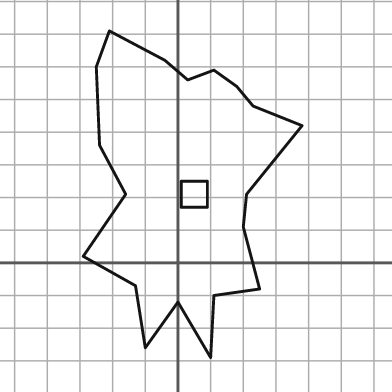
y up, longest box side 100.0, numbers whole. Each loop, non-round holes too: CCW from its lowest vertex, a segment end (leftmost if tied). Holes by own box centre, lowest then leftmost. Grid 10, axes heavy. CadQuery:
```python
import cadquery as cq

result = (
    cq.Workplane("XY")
    .moveTo(10.0, -29.0)
    .lineTo(11.0, -10.0)
    .lineTo(25.0, -8.0)
    .lineTo(20.0, 11.0)
    .lineTo(21.0, 21.0)
    .lineTo(38.0, 42.0)
    .lineTo(23.0, 48.0)
    .lineTo(18.0, 54.0)
    .lineTo(11.0, 59.0)
    .lineTo(3.0, 56.0)
    .lineTo(-4.0, 62.0)
    .lineTo(-21.0, 71.0)
    .lineTo(-25.0, 60.0)
    .lineTo(-24.0, 36.0)
    .lineTo(-16.0, 21.0)
    .lineTo(-29.0, 2.0)
    .lineTo(-13.0, -7.0)
    .lineTo(-10.0, -26.0)
    .lineTo(0.0, -12.0)
    .close()
    .moveTo(1.0, 17.0)
    .lineTo(9.0, 17.0)
    .lineTo(9.0, 25.0)
    .lineTo(1.0, 25.0)
    .close()
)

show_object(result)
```